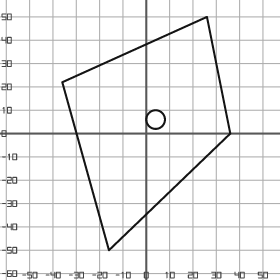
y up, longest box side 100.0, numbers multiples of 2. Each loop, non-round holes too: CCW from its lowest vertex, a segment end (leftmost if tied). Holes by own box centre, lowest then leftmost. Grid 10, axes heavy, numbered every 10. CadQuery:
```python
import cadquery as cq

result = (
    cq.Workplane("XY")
    .moveTo(-16.0, -50.0)
    .lineTo(36.0, 0.0)
    .lineTo(26.0, 50.0)
    .lineTo(-36.0, 22.0)
    .close()
    .moveTo(4.0, 6.0)
    .circle(4.0)
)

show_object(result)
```